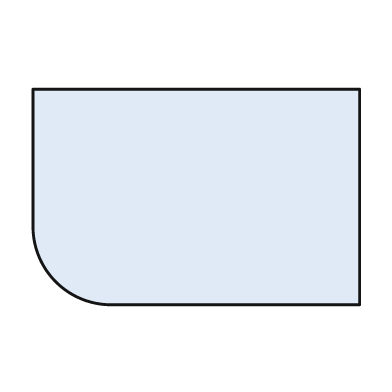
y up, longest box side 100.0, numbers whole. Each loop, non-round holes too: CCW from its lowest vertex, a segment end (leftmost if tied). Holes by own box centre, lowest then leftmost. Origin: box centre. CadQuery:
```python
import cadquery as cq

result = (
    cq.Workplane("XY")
    .moveTo(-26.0, -33.0)
    .lineTo(50.0, -33.0)
    .lineTo(50.0, 33.0)
    .lineTo(-50.0, 33.0)
    .lineTo(-50.0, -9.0)
    .threePointArc((-43.0, -26.0), (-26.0, -33.0))
    .close()
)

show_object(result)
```